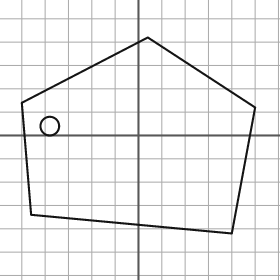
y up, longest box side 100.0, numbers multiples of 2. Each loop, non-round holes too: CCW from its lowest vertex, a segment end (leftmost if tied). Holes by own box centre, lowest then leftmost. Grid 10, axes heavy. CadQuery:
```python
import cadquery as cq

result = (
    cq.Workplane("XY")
    .moveTo(40.0, -42.0)
    .lineTo(50.0, 12.0)
    .lineTo(4.0, 42.0)
    .lineTo(-50.0, 14.0)
    .lineTo(-46.0, -34.0)
    .close()
    .moveTo(-38.0, 4.0)
    .circle(4.0)
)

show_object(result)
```